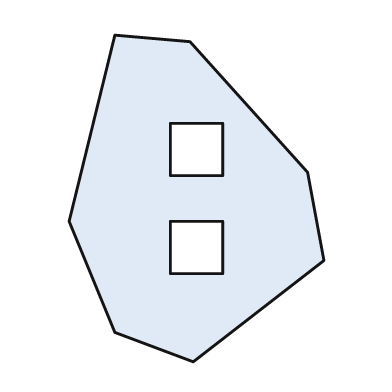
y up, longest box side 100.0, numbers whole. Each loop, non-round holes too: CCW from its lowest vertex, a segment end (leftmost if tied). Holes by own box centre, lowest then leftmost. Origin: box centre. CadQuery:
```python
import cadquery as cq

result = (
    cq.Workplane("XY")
    .moveTo(-1.0, -50.0)
    .lineTo(39.0, -19.0)
    .lineTo(34.0, 8.0)
    .lineTo(-2.0, 48.0)
    .lineTo(-25.0, 50.0)
    .lineTo(-39.0, -7.0)
    .lineTo(-25.0, -41.0)
    .close()
    .moveTo(-8.0, -23.0)
    .lineTo(8.0, -23.0)
    .lineTo(8.0, -7.0)
    .lineTo(-8.0, -7.0)
    .close()
    .moveTo(-8.0, 7.0)
    .lineTo(8.0, 7.0)
    .lineTo(8.0, 23.0)
    .lineTo(-8.0, 23.0)
    .close()
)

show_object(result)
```